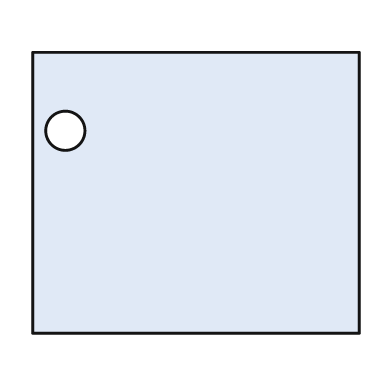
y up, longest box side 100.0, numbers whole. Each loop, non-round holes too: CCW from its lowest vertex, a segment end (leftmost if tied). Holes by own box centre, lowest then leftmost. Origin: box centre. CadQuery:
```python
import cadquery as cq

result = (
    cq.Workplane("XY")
    .moveTo(-50.0, -43.0)
    .lineTo(50.0, -43.0)
    .lineTo(50.0, 43.0)
    .lineTo(-50.0, 43.0)
    .close()
    .moveTo(-40.0, 19.0)
    .circle(6.0)
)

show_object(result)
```